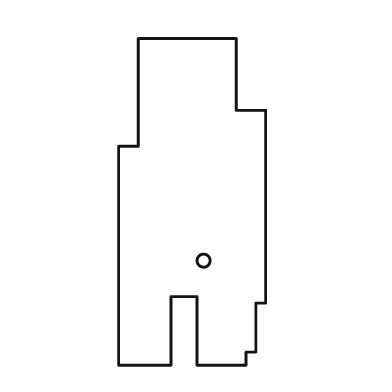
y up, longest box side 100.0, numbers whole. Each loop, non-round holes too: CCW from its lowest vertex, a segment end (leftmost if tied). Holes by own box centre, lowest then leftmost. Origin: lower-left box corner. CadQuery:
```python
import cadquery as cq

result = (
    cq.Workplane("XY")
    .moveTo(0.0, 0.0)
    .lineTo(16.0, 0.0)
    .lineTo(16.0, 21.0)
    .lineTo(24.0, 21.0)
    .lineTo(24.0, 0.0)
    .lineTo(39.0, 0.0)
    .lineTo(39.0, 4.0)
    .lineTo(42.0, 4.0)
    .lineTo(42.0, 19.0)
    .lineTo(45.0, 19.0)
    .lineTo(45.0, 78.0)
    .lineTo(36.0, 78.0)
    .lineTo(36.0, 100.0)
    .lineTo(6.0, 100.0)
    .lineTo(6.0, 67.0)
    .lineTo(0.0, 67.0)
    .close()
    .moveTo(26.0, 32.0)
    .circle(2.0)
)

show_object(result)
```